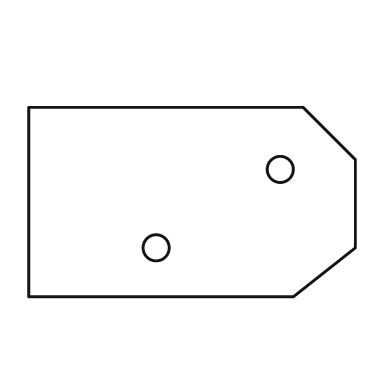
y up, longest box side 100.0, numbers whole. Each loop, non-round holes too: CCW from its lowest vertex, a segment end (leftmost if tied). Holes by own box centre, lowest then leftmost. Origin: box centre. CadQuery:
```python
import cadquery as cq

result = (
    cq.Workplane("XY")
    .moveTo(-50.0, -29.0)
    .lineTo(31.0, -29.0)
    .lineTo(50.0, -14.0)
    .lineTo(50.0, 13.0)
    .lineTo(34.0, 29.0)
    .lineTo(-50.0, 29.0)
    .close()
    .moveTo(-11.0, -14.0)
    .circle(4.0)
    .moveTo(27.0, 10.0)
    .circle(4.0)
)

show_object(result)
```